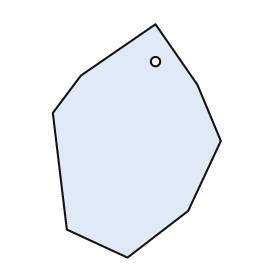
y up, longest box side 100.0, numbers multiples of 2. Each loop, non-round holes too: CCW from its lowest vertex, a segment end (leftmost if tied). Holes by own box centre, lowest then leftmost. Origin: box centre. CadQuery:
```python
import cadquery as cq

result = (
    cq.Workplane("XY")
    .moveTo(-4.0, -50.0)
    .lineTo(22.0, -30.0)
    .lineTo(36.0, 0.0)
    .lineTo(26.0, 24.0)
    .lineTo(8.0, 50.0)
    .lineTo(-24.0, 28.0)
    .lineTo(-36.0, 12.0)
    .lineTo(-30.0, -38.0)
    .close()
    .moveTo(8.0, 34.0)
    .circle(2.0)
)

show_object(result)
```